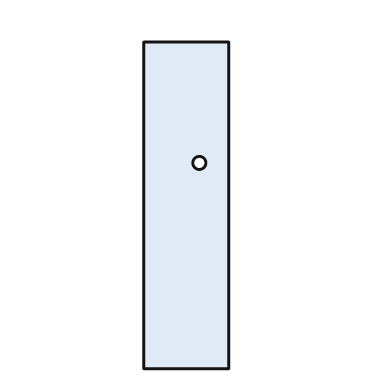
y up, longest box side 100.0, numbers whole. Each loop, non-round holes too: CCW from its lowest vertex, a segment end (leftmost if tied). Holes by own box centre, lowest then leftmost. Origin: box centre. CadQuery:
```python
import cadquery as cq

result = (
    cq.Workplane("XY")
    .moveTo(-13.0, -50.0)
    .lineTo(13.0, -50.0)
    .lineTo(13.0, 50.0)
    .lineTo(-13.0, 50.0)
    .close()
    .moveTo(4.0, 13.0)
    .circle(2.0)
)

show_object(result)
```